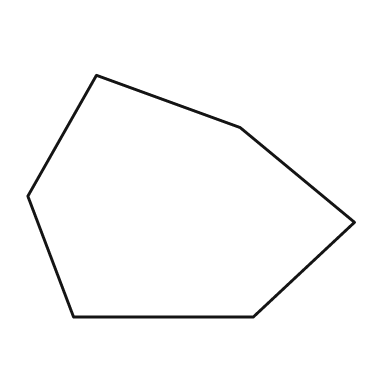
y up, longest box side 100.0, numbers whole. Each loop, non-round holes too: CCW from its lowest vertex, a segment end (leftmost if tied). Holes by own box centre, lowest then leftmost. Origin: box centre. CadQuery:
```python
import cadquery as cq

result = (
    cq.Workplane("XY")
    .moveTo(-36.0, -37.0)
    .lineTo(19.0, -37.0)
    .lineTo(50.0, -8.0)
    .lineTo(15.0, 21.0)
    .lineTo(-29.0, 37.0)
    .lineTo(-50.0, 0.0)
    .close()
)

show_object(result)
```